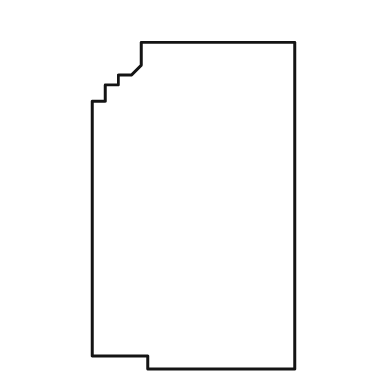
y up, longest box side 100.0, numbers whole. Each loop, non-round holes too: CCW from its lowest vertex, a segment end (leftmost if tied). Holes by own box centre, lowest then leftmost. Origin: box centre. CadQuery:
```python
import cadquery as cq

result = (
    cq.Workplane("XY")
    .moveTo(-14.0, -50.0)
    .lineTo(31.0, -50.0)
    .lineTo(31.0, 50.0)
    .lineTo(-16.0, 50.0)
    .lineTo(-16.0, 43.0)
    .lineTo(-19.0, 40.0)
    .lineTo(-23.0, 40.0)
    .lineTo(-23.0, 37.0)
    .lineTo(-27.0, 37.0)
    .lineTo(-27.0, 32.0)
    .lineTo(-31.0, 32.0)
    .lineTo(-31.0, -46.0)
    .lineTo(-14.0, -46.0)
    .close()
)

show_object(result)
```